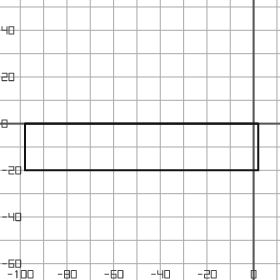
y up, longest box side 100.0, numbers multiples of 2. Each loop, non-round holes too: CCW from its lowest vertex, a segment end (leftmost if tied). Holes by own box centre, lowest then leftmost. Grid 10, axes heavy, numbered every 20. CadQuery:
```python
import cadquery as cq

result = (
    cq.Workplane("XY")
    .moveTo(-98.0, -20.0)
    .lineTo(2.0, -20.0)
    .lineTo(2.0, 0.0)
    .lineTo(-98.0, 0.0)
    .close()
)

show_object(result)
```